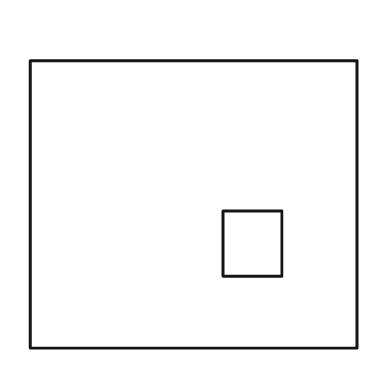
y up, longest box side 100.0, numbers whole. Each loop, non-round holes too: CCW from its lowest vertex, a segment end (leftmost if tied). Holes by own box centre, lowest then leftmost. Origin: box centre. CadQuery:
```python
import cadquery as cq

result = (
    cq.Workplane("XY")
    .moveTo(-50.0, -44.0)
    .lineTo(50.0, -44.0)
    .lineTo(50.0, 44.0)
    .lineTo(-50.0, 44.0)
    .close()
    .moveTo(9.0, -22.0)
    .lineTo(27.0, -22.0)
    .lineTo(27.0, -2.0)
    .lineTo(9.0, -2.0)
    .close()
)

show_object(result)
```